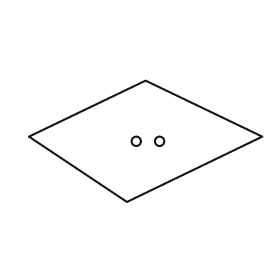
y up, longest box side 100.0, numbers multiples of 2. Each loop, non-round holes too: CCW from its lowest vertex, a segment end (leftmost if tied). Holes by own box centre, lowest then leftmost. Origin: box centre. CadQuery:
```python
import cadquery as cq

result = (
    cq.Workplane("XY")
    .moveTo(-8.0, -26.0)
    .lineTo(50.0, 2.0)
    .lineTo(0.0, 26.0)
    .lineTo(-50.0, 2.0)
    .close()
    .moveTo(-4.0, 0.0)
    .circle(2.0)
    .moveTo(6.0, 0.0)
    .circle(2.0)
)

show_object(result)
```